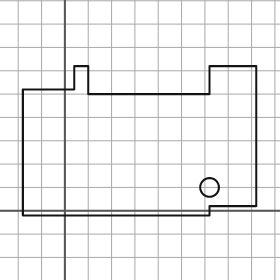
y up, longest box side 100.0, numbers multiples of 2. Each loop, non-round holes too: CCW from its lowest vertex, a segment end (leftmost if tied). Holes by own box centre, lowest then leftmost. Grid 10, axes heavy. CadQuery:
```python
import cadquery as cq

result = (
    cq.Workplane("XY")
    .moveTo(-18.0, -2.0)
    .lineTo(62.0, -2.0)
    .lineTo(62.0, 2.0)
    .lineTo(82.0, 2.0)
    .lineTo(82.0, 62.0)
    .lineTo(62.0, 62.0)
    .lineTo(62.0, 50.0)
    .lineTo(10.0, 50.0)
    .lineTo(10.0, 62.0)
    .lineTo(4.0, 62.0)
    .lineTo(4.0, 52.0)
    .lineTo(-18.0, 52.0)
    .close()
    .moveTo(62.0, 10.0)
    .circle(4.0)
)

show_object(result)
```